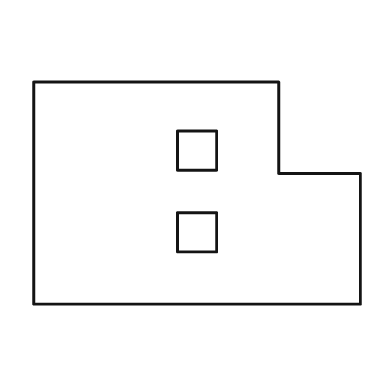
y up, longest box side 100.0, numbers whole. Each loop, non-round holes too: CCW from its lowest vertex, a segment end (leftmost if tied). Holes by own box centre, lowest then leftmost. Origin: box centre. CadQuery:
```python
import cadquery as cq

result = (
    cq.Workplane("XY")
    .moveTo(-50.0, -34.0)
    .lineTo(50.0, -34.0)
    .lineTo(50.0, 6.0)
    .lineTo(25.0, 6.0)
    .lineTo(25.0, 34.0)
    .lineTo(-50.0, 34.0)
    .close()
    .moveTo(-6.0, -18.0)
    .lineTo(6.0, -18.0)
    .lineTo(6.0, -6.0)
    .lineTo(-6.0, -6.0)
    .close()
    .moveTo(-6.0, 7.0)
    .lineTo(6.0, 7.0)
    .lineTo(6.0, 19.0)
    .lineTo(-6.0, 19.0)
    .close()
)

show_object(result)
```